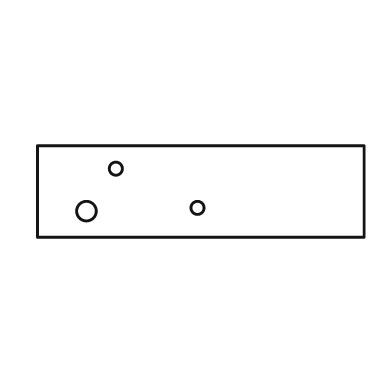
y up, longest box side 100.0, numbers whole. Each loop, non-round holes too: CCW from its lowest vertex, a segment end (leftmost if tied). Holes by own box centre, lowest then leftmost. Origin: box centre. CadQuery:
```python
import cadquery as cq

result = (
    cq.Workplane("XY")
    .moveTo(-50.0, -14.0)
    .lineTo(50.0, -14.0)
    .lineTo(50.0, 14.0)
    .lineTo(-50.0, 14.0)
    .close()
    .moveTo(-35.0, -6.0)
    .circle(3.0)
    .moveTo(-1.0, -5.0)
    .circle(2.0)
    .moveTo(-26.0, 7.0)
    .circle(2.0)
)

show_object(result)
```